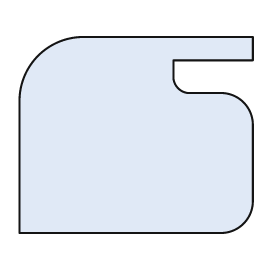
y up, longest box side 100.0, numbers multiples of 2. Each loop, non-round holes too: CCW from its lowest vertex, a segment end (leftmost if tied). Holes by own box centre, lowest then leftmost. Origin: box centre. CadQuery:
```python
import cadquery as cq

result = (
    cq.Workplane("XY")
    .moveTo(-50.0, -42.0)
    .lineTo(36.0, -42.0)
    .threePointArc((46.0, -38.0), (50.0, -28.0))
    .lineTo(50.0, 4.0)
    .threePointArc((46.0, 14.0), (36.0, 18.0))
    .lineTo(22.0, 18.0)
    .threePointArc((18.0, 20.0), (16.0, 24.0))
    .lineTo(16.0, 32.0)
    .lineTo(50.0, 32.0)
    .lineTo(50.0, 42.0)
    .lineTo(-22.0, 42.0)
    .threePointArc((-42.0, 34.0), (-50.0, 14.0))
    .close()
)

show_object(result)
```